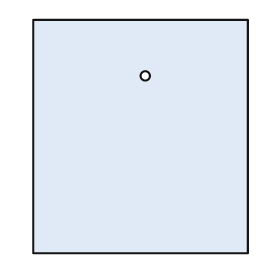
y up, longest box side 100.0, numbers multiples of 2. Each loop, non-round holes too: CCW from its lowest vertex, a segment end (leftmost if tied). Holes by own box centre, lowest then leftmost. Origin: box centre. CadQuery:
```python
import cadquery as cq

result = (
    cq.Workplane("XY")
    .moveTo(-46.0, -50.0)
    .lineTo(46.0, -50.0)
    .lineTo(46.0, 50.0)
    .lineTo(-46.0, 50.0)
    .close()
    .moveTo(2.0, 26.0)
    .circle(2.0)
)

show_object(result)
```